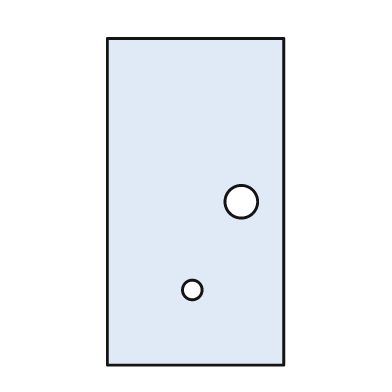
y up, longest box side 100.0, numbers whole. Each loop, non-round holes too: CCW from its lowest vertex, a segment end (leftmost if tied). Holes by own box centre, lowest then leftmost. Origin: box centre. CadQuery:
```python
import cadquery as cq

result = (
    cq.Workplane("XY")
    .moveTo(-27.0, -50.0)
    .lineTo(27.0, -50.0)
    .lineTo(27.0, 50.0)
    .lineTo(-27.0, 50.0)
    .close()
    .moveTo(-1.0, -27.0)
    .circle(3.0)
    .moveTo(14.0, 0.0)
    .circle(5.0)
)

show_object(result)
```